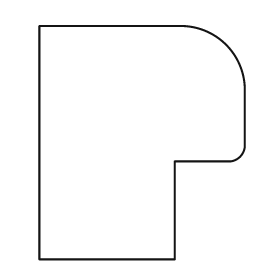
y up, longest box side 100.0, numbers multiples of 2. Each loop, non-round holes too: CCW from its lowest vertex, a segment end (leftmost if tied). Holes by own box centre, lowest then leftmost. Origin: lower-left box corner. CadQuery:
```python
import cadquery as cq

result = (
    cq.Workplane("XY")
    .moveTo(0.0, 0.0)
    .lineTo(58.0, 0.0)
    .lineTo(58.0, 42.0)
    .lineTo(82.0, 42.0)
    .threePointArc((86.0, 44.0), (88.0, 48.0))
    .lineTo(88.0, 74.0)
    .threePointArc((80.0, 92.0), (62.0, 100.0))
    .lineTo(0.0, 100.0)
    .close()
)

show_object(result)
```